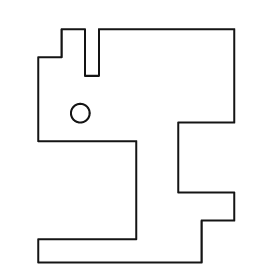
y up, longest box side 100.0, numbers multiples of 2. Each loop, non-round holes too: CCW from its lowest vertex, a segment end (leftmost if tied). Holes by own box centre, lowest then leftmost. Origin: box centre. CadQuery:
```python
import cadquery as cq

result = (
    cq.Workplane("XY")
    .moveTo(-42.0, -50.0)
    .lineTo(28.0, -50.0)
    .lineTo(28.0, -32.0)
    .lineTo(42.0, -32.0)
    .lineTo(42.0, -20.0)
    .lineTo(18.0, -20.0)
    .lineTo(18.0, 10.0)
    .lineTo(42.0, 10.0)
    .lineTo(42.0, 50.0)
    .lineTo(-16.0, 50.0)
    .lineTo(-16.0, 30.0)
    .lineTo(-22.0, 30.0)
    .lineTo(-22.0, 50.0)
    .lineTo(-32.0, 50.0)
    .lineTo(-32.0, 38.0)
    .lineTo(-42.0, 38.0)
    .lineTo(-42.0, 2.0)
    .lineTo(0.0, 2.0)
    .lineTo(0.0, -40.0)
    .lineTo(-42.0, -40.0)
    .close()
    .moveTo(-24.0, 14.0)
    .circle(4.0)
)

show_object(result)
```